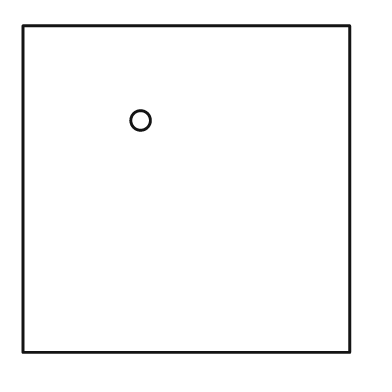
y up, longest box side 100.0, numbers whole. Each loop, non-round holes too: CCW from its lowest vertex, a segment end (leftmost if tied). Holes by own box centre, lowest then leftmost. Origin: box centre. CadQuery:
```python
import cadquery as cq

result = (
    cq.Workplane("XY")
    .moveTo(-50.0, -50.0)
    .lineTo(50.0, -50.0)
    .lineTo(50.0, 50.0)
    .lineTo(-50.0, 50.0)
    .close()
    .moveTo(-14.0, 21.0)
    .circle(3.0)
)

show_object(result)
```